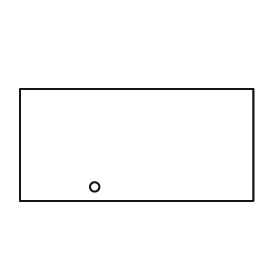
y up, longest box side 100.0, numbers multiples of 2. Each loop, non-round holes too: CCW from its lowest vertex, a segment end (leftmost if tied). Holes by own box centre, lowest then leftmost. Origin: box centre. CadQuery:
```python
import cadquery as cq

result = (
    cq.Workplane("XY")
    .moveTo(-50.0, -24.0)
    .lineTo(50.0, -24.0)
    .lineTo(50.0, 24.0)
    .lineTo(-50.0, 24.0)
    .close()
    .moveTo(-18.0, -18.0)
    .circle(2.0)
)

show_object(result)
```